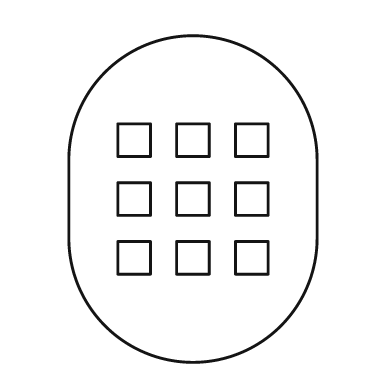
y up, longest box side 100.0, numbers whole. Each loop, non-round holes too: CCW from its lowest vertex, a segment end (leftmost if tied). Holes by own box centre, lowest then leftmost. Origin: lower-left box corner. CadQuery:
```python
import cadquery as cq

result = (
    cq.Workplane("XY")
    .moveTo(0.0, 38.0)
    .threePointArc((38.0, 0.0), (76.0, 38.0))
    .lineTo(76.0, 62.0)
    .threePointArc((38.0, 100.0), (0.0, 62.0))
    .close()
    .moveTo(15.0, 27.0)
    .lineTo(25.0, 27.0)
    .lineTo(25.0, 37.0)
    .lineTo(15.0, 37.0)
    .close()
    .moveTo(33.0, 27.0)
    .lineTo(43.0, 27.0)
    .lineTo(43.0, 37.0)
    .lineTo(33.0, 37.0)
    .close()
    .moveTo(51.0, 27.0)
    .lineTo(61.0, 27.0)
    .lineTo(61.0, 37.0)
    .lineTo(51.0, 37.0)
    .close()
    .moveTo(15.0, 45.0)
    .lineTo(25.0, 45.0)
    .lineTo(25.0, 55.0)
    .lineTo(15.0, 55.0)
    .close()
    .moveTo(33.0, 45.0)
    .lineTo(43.0, 45.0)
    .lineTo(43.0, 55.0)
    .lineTo(33.0, 55.0)
    .close()
    .moveTo(51.0, 45.0)
    .lineTo(61.0, 45.0)
    .lineTo(61.0, 55.0)
    .lineTo(51.0, 55.0)
    .close()
    .moveTo(15.0, 63.0)
    .lineTo(25.0, 63.0)
    .lineTo(25.0, 73.0)
    .lineTo(15.0, 73.0)
    .close()
    .moveTo(33.0, 63.0)
    .lineTo(43.0, 63.0)
    .lineTo(43.0, 73.0)
    .lineTo(33.0, 73.0)
    .close()
    .moveTo(51.0, 63.0)
    .lineTo(61.0, 63.0)
    .lineTo(61.0, 73.0)
    .lineTo(51.0, 73.0)
    .close()
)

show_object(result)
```